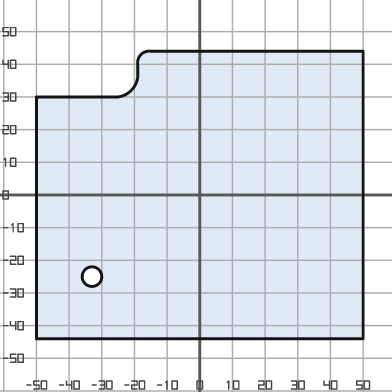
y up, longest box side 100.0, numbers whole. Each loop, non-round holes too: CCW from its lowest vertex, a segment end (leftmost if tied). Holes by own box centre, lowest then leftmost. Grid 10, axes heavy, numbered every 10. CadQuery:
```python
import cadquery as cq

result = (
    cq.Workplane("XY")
    .moveTo(-50.0, -44.0)
    .lineTo(50.0, -44.0)
    .lineTo(50.0, 44.0)
    .lineTo(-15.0, 44.0)
    .threePointArc((-18.0, 43.0), (-19.0, 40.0))
    .lineTo(-19.0, 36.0)
    .threePointArc((-21.0, 32.0), (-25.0, 30.0))
    .lineTo(-50.0, 30.0)
    .close()
    .moveTo(-33.0, -25.0)
    .circle(3.0)
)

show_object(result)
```